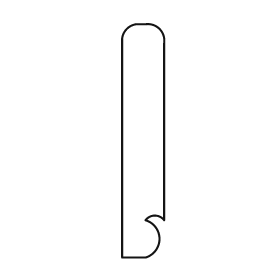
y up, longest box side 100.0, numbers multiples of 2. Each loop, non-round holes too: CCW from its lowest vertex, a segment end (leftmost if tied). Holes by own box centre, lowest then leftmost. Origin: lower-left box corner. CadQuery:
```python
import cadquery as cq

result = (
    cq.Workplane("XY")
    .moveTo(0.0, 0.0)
    .lineTo(10.0, 0.0)
    .threePointArc((16.0, 8.0), (10.0, 16.0))
    .threePointArc((14.0, 18.0), (18.0, 16.0))
    .lineTo(18.0, 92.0)
    .threePointArc((16.0, 98.0), (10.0, 100.0))
    .lineTo(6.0, 100.0)
    .threePointArc((2.0, 98.0), (0.0, 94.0))
    .close()
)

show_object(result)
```